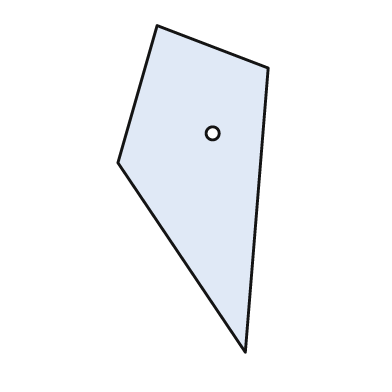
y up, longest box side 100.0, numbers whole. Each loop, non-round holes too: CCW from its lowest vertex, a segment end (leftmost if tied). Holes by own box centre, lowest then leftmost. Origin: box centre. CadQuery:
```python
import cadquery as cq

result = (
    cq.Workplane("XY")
    .moveTo(16.0, -50.0)
    .lineTo(23.0, 37.0)
    .lineTo(-11.0, 50.0)
    .lineTo(-23.0, 8.0)
    .close()
    .moveTo(6.0, 17.0)
    .circle(2.0)
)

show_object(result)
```